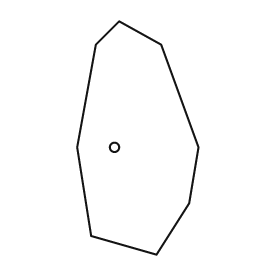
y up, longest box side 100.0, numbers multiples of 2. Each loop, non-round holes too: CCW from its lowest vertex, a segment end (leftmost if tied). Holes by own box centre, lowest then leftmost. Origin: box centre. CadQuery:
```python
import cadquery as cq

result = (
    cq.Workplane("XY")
    .moveTo(8.0, -50.0)
    .lineTo(22.0, -28.0)
    .lineTo(26.0, -4.0)
    .lineTo(10.0, 40.0)
    .lineTo(-8.0, 50.0)
    .lineTo(-18.0, 40.0)
    .lineTo(-26.0, -4.0)
    .lineTo(-20.0, -42.0)
    .close()
    .moveTo(-10.0, -4.0)
    .circle(2.0)
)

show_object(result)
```